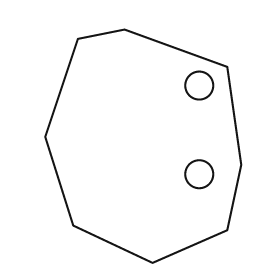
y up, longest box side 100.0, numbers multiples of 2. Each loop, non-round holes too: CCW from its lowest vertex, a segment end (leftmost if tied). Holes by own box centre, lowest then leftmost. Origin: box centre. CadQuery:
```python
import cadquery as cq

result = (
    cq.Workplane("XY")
    .moveTo(4.0, -50.0)
    .lineTo(36.0, -36.0)
    .lineTo(42.0, -8.0)
    .lineTo(36.0, 34.0)
    .lineTo(-8.0, 50.0)
    .lineTo(-28.0, 46.0)
    .lineTo(-42.0, 4.0)
    .lineTo(-30.0, -34.0)
    .close()
    .moveTo(24.0, -12.0)
    .circle(6.0)
    .moveTo(24.0, 26.0)
    .circle(6.0)
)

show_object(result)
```